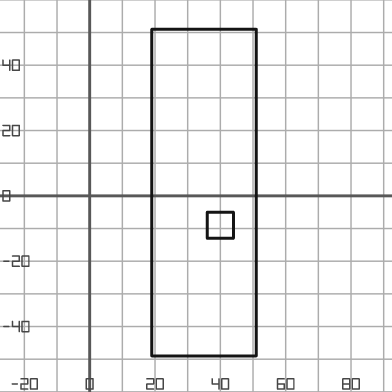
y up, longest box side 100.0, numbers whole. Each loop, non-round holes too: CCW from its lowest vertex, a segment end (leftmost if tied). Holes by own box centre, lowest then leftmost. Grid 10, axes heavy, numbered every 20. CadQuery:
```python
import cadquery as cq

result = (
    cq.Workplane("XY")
    .moveTo(19.0, -49.0)
    .lineTo(51.0, -49.0)
    .lineTo(51.0, 51.0)
    .lineTo(19.0, 51.0)
    .close()
    .moveTo(36.0, -13.0)
    .lineTo(44.0, -13.0)
    .lineTo(44.0, -5.0)
    .lineTo(36.0, -5.0)
    .close()
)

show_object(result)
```